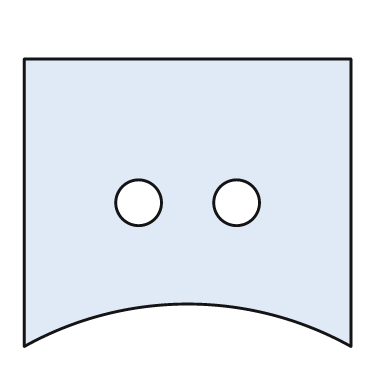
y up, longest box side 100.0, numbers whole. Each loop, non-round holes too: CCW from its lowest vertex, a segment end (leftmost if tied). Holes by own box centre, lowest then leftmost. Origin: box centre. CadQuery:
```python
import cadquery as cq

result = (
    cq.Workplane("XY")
    .moveTo(-50.0, -44.0)
    .threePointArc((0.0, -31.0), (50.0, -44.0))
    .lineTo(50.0, 44.0)
    .lineTo(-50.0, 44.0)
    .close()
    .moveTo(-15.0, 0.0)
    .circle(7.0)
    .moveTo(15.0, 0.0)
    .circle(7.0)
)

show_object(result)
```